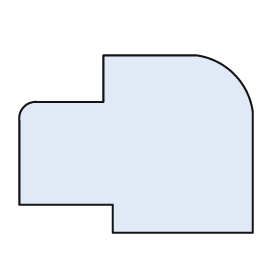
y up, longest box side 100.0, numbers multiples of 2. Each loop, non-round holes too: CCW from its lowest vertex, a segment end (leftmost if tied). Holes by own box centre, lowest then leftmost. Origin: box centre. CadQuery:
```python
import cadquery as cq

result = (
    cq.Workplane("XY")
    .moveTo(-10.0, -38.0)
    .lineTo(50.0, -38.0)
    .lineTo(50.0, 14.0)
    .threePointArc((42.0, 30.0), (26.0, 38.0))
    .lineTo(-14.0, 38.0)
    .lineTo(-14.0, 18.0)
    .lineTo(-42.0, 18.0)
    .threePointArc((-48.0, 16.0), (-50.0, 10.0))
    .lineTo(-50.0, -26.0)
    .lineTo(-10.0, -26.0)
    .close()
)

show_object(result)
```